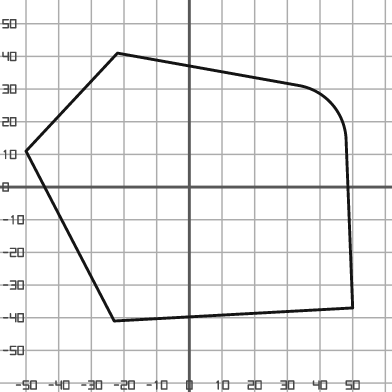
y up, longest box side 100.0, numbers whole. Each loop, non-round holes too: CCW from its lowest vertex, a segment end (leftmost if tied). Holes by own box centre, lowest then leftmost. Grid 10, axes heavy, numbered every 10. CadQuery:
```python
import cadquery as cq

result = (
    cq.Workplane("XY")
    .moveTo(-23.0, -41.0)
    .lineTo(50.0, -37.0)
    .lineTo(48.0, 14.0)
    .threePointArc((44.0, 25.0), (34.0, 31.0))
    .lineTo(-22.0, 41.0)
    .lineTo(-50.0, 11.0)
    .close()
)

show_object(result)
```